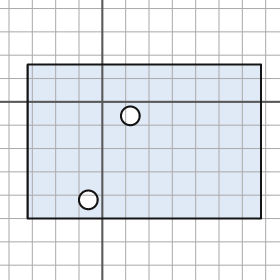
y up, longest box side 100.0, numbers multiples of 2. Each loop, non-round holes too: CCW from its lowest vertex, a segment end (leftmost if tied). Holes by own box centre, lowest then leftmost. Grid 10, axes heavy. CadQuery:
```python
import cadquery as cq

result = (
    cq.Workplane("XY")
    .moveTo(-32.0, -50.0)
    .lineTo(68.0, -50.0)
    .lineTo(68.0, 16.0)
    .lineTo(-32.0, 16.0)
    .close()
    .moveTo(-6.0, -42.0)
    .circle(4.0)
    .moveTo(12.0, -6.0)
    .circle(4.0)
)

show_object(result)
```